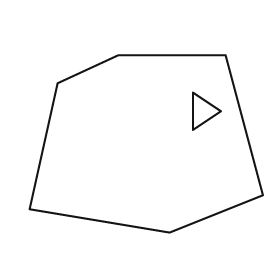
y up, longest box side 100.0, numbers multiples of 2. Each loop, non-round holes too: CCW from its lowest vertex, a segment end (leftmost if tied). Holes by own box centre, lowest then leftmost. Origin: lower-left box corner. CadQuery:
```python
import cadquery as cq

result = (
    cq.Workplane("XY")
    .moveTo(60.0, 0.0)
    .lineTo(100.0, 16.0)
    .lineTo(84.0, 76.0)
    .lineTo(38.0, 76.0)
    .lineTo(12.0, 64.0)
    .lineTo(0.0, 10.0)
    .close()
    .moveTo(70.0, 44.0)
    .lineTo(82.0, 52.0)
    .lineTo(70.0, 60.0)
    .close()
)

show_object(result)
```